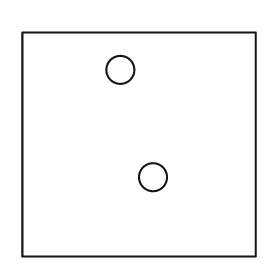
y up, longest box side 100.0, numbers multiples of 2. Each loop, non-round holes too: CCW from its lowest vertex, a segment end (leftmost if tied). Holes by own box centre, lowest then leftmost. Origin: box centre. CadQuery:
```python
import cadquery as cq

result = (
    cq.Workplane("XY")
    .moveTo(-50.0, -48.0)
    .lineTo(50.0, -48.0)
    .lineTo(50.0, 48.0)
    .lineTo(-50.0, 48.0)
    .close()
    .moveTo(6.0, -14.0)
    .circle(6.0)
    .moveTo(-8.0, 32.0)
    .circle(6.0)
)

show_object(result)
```